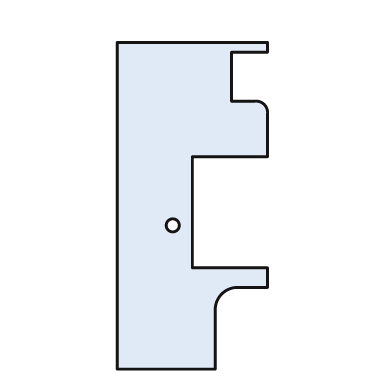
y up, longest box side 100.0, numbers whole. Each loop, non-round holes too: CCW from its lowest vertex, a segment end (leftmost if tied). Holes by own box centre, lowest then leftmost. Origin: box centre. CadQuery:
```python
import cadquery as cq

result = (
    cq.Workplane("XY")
    .moveTo(-23.0, -50.0)
    .lineTo(7.0, -50.0)
    .lineTo(7.0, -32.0)
    .threePointArc((9.0, -27.0), (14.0, -25.0))
    .lineTo(23.0, -25.0)
    .lineTo(23.0, -19.0)
    .lineTo(0.0, -19.0)
    .lineTo(0.0, 15.0)
    .lineTo(23.0, 15.0)
    .lineTo(23.0, 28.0)
    .threePointArc((22.0, 31.0), (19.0, 32.0))
    .lineTo(12.0, 32.0)
    .lineTo(12.0, 47.0)
    .lineTo(23.0, 47.0)
    .lineTo(23.0, 50.0)
    .lineTo(-23.0, 50.0)
    .close()
    .moveTo(-6.0, -6.0)
    .circle(2.0)
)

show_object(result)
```